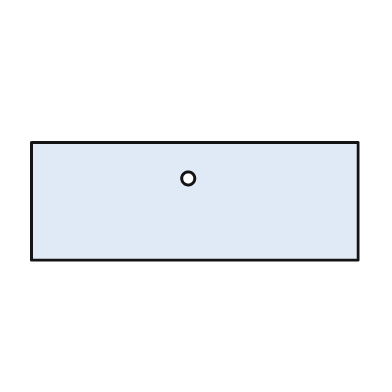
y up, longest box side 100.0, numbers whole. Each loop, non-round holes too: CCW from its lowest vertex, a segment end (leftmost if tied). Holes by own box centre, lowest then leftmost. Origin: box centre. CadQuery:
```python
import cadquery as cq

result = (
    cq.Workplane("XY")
    .moveTo(-50.0, -18.0)
    .lineTo(50.0, -18.0)
    .lineTo(50.0, 18.0)
    .lineTo(-50.0, 18.0)
    .close()
    .moveTo(-2.0, 7.0)
    .circle(2.0)
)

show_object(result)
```